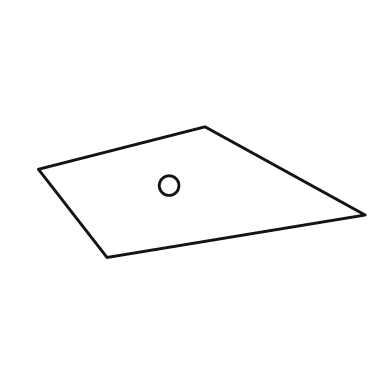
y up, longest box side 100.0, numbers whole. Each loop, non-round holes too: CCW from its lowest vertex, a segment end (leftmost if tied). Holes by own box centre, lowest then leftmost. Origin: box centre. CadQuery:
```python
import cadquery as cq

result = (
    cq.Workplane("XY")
    .moveTo(-29.0, -20.0)
    .lineTo(50.0, -7.0)
    .lineTo(1.0, 20.0)
    .lineTo(-50.0, 7.0)
    .close()
    .moveTo(-10.0, 2.0)
    .circle(3.0)
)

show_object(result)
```